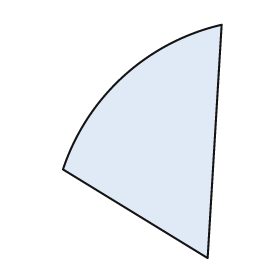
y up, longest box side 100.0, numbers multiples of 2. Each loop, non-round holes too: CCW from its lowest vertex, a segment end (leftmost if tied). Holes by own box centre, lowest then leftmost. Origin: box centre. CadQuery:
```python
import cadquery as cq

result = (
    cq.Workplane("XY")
    .moveTo(28.0, -50.0)
    .lineTo(34.0, 50.0)
    .threePointArc((-8.0, 28.0), (-34.0, -12.0))
    .close()
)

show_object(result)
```